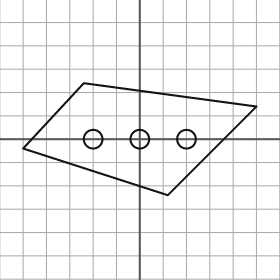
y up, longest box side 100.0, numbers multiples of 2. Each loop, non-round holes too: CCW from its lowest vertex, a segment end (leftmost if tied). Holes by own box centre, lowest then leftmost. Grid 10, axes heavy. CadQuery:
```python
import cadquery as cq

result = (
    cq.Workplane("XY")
    .moveTo(12.0, -24.0)
    .lineTo(50.0, 14.0)
    .lineTo(-24.0, 24.0)
    .lineTo(-50.0, -4.0)
    .close()
    .moveTo(-20.0, 0.0)
    .circle(4.0)
    .moveTo(0.0, 0.0)
    .circle(4.0)
    .moveTo(20.0, 0.0)
    .circle(4.0)
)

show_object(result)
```